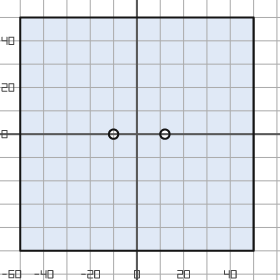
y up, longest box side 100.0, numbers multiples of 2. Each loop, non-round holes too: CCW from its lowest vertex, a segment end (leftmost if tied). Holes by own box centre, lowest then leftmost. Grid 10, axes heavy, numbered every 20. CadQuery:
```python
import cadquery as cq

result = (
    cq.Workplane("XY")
    .moveTo(-50.0, -50.0)
    .lineTo(50.0, -50.0)
    .lineTo(50.0, 50.0)
    .lineTo(-50.0, 50.0)
    .close()
    .moveTo(-10.0, 0.0)
    .circle(2.0)
    .moveTo(12.0, 0.0)
    .circle(2.0)
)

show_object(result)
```